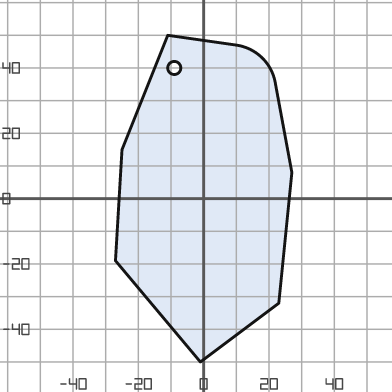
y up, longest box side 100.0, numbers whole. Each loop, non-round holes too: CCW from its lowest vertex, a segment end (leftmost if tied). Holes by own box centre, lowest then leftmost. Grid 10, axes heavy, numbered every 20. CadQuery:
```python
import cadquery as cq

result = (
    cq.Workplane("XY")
    .moveTo(-1.0, -50.0)
    .lineTo(23.0, -32.0)
    .lineTo(27.0, 8.0)
    .lineTo(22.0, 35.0)
    .threePointArc((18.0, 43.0), (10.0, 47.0))
    .lineTo(-11.0, 50.0)
    .lineTo(-25.0, 15.0)
    .lineTo(-27.0, -19.0)
    .close()
    .moveTo(-9.0, 40.0)
    .circle(2.0)
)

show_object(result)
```